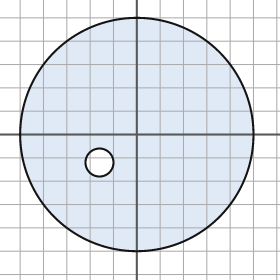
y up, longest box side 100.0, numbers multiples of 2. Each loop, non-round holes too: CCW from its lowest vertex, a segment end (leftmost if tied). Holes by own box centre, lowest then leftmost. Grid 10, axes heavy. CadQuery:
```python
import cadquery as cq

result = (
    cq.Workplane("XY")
    .moveTo(0.0, 0.0)
    .circle(50.0)
    .moveTo(-16.0, -12.0)
    .circle(6.0)
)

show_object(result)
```